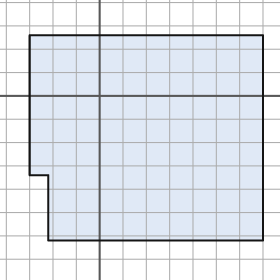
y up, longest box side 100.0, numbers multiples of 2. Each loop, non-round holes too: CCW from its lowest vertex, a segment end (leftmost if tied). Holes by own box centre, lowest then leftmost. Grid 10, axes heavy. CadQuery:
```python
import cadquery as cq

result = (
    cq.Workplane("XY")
    .moveTo(-22.0, -62.0)
    .lineTo(70.0, -62.0)
    .lineTo(70.0, 26.0)
    .lineTo(-30.0, 26.0)
    .lineTo(-30.0, -34.0)
    .lineTo(-22.0, -34.0)
    .close()
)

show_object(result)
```